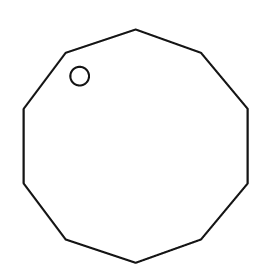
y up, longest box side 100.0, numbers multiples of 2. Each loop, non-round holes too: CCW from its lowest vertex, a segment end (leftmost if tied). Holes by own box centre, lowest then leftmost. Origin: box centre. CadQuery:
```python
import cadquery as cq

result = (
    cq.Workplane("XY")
    .moveTo(0.0, -50.0)
    .lineTo(28.0, -40.0)
    .lineTo(48.0, -16.0)
    .lineTo(48.0, 16.0)
    .lineTo(28.0, 40.0)
    .lineTo(0.0, 50.0)
    .lineTo(-30.0, 40.0)
    .lineTo(-48.0, 16.0)
    .lineTo(-48.0, -16.0)
    .lineTo(-30.0, -40.0)
    .close()
    .moveTo(-24.0, 30.0)
    .circle(4.0)
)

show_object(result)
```